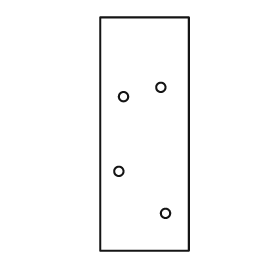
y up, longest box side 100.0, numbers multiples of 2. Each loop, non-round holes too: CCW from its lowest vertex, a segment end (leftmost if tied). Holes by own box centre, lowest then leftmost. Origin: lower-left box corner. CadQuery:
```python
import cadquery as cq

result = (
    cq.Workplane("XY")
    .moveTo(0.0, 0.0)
    .lineTo(38.0, 0.0)
    .lineTo(38.0, 100.0)
    .lineTo(0.0, 100.0)
    .close()
    .moveTo(28.0, 16.0)
    .circle(2.0)
    .moveTo(8.0, 34.0)
    .circle(2.0)
    .moveTo(10.0, 66.0)
    .circle(2.0)
    .moveTo(26.0, 70.0)
    .circle(2.0)
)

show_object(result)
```